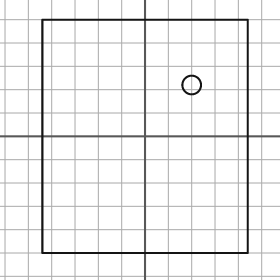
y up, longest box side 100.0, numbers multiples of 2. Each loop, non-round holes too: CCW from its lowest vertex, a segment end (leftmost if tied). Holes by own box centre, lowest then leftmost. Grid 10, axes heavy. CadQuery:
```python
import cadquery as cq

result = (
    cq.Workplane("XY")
    .moveTo(-44.0, -50.0)
    .lineTo(44.0, -50.0)
    .lineTo(44.0, 50.0)
    .lineTo(-44.0, 50.0)
    .close()
    .moveTo(20.0, 22.0)
    .circle(4.0)
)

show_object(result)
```